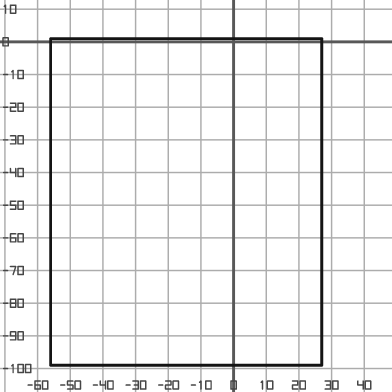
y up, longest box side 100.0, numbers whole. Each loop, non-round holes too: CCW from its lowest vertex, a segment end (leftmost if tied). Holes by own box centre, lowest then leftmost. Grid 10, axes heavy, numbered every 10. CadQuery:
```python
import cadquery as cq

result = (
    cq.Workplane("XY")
    .moveTo(-56.0, -99.0)
    .lineTo(27.0, -99.0)
    .lineTo(27.0, 1.0)
    .lineTo(-56.0, 1.0)
    .close()
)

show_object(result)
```